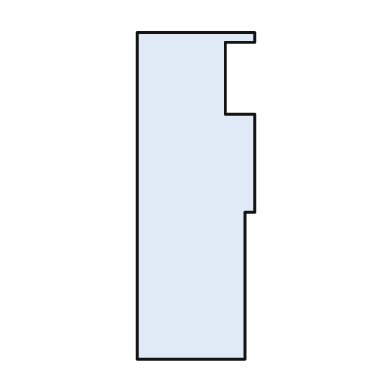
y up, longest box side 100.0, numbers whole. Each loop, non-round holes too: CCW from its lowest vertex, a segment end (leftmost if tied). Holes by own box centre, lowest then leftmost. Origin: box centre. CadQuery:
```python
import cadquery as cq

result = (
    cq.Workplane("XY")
    .moveTo(-18.0, -50.0)
    .lineTo(15.0, -50.0)
    .lineTo(15.0, -5.0)
    .lineTo(18.0, -5.0)
    .lineTo(18.0, 25.0)
    .lineTo(9.0, 25.0)
    .lineTo(9.0, 47.0)
    .lineTo(18.0, 47.0)
    .lineTo(18.0, 50.0)
    .lineTo(-18.0, 50.0)
    .close()
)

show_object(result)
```